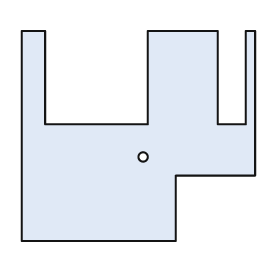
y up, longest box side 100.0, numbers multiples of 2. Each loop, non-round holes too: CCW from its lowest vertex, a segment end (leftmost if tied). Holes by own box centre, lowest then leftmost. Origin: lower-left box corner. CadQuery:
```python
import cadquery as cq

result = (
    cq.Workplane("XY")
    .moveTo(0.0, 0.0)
    .lineTo(66.0, 0.0)
    .lineTo(66.0, 28.0)
    .lineTo(100.0, 28.0)
    .lineTo(100.0, 90.0)
    .lineTo(96.0, 90.0)
    .lineTo(96.0, 50.0)
    .lineTo(84.0, 50.0)
    .lineTo(84.0, 90.0)
    .lineTo(54.0, 90.0)
    .lineTo(54.0, 50.0)
    .lineTo(10.0, 50.0)
    .lineTo(10.0, 90.0)
    .lineTo(0.0, 90.0)
    .close()
    .moveTo(52.0, 36.0)
    .circle(2.0)
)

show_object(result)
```